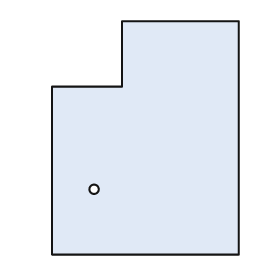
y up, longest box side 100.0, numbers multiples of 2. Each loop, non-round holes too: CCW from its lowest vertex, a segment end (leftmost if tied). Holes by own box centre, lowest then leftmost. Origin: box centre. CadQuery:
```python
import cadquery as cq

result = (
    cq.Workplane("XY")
    .moveTo(-40.0, -50.0)
    .lineTo(40.0, -50.0)
    .lineTo(40.0, 50.0)
    .lineTo(-10.0, 50.0)
    .lineTo(-10.0, 22.0)
    .lineTo(-40.0, 22.0)
    .close()
    .moveTo(-22.0, -22.0)
    .circle(2.0)
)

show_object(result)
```